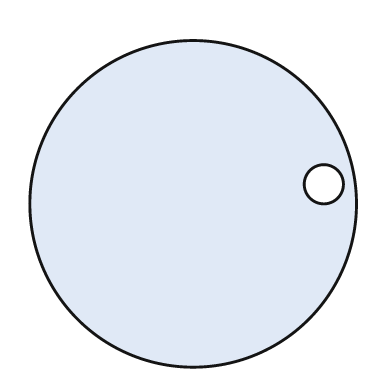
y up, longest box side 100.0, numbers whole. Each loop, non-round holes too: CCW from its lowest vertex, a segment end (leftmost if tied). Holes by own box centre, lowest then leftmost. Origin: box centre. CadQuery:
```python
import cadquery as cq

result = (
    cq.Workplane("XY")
    .moveTo(0.0, 0.0)
    .circle(50.0)
    .moveTo(40.0, 6.0)
    .circle(6.0)
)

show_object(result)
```